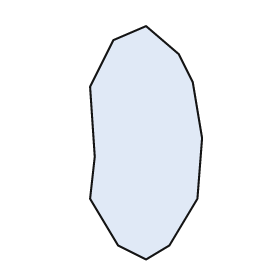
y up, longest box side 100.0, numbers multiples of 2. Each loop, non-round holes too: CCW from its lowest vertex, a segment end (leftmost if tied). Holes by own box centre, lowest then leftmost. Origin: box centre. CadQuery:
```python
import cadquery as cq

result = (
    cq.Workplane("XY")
    .moveTo(0.0, -50.0)
    .lineTo(10.0, -44.0)
    .lineTo(22.0, -24.0)
    .lineTo(24.0, 2.0)
    .lineTo(20.0, 26.0)
    .lineTo(14.0, 38.0)
    .lineTo(0.0, 50.0)
    .lineTo(-14.0, 44.0)
    .lineTo(-24.0, 24.0)
    .lineTo(-22.0, -6.0)
    .lineTo(-24.0, -24.0)
    .lineTo(-12.0, -44.0)
    .close()
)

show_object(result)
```